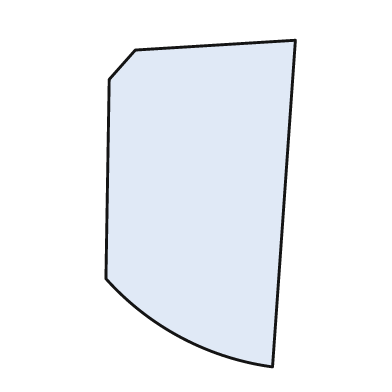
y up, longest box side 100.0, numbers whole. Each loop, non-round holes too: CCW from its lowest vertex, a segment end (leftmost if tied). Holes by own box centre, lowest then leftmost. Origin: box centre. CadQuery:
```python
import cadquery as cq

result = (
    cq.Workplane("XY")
    .moveTo(22.0, -50.0)
    .lineTo(29.0, 50.0)
    .lineTo(-20.0, 47.0)
    .lineTo(-28.0, 38.0)
    .lineTo(-29.0, -23.0)
    .threePointArc((-6.0, -41.0), (22.0, -50.0))
    .close()
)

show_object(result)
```